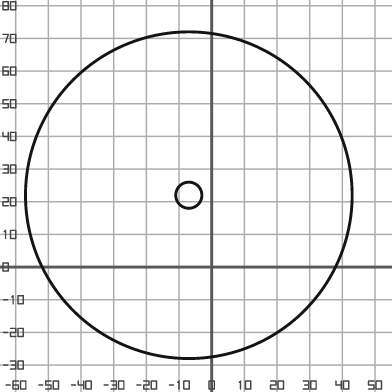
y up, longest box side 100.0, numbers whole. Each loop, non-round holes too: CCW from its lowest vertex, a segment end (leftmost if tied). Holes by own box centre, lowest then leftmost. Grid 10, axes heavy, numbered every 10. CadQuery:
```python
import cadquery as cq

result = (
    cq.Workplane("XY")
    .moveTo(-7.0, 22.0)
    .circle(50.0)
    .moveTo(-7.0, 22.0)
    .circle(4.0)
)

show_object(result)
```